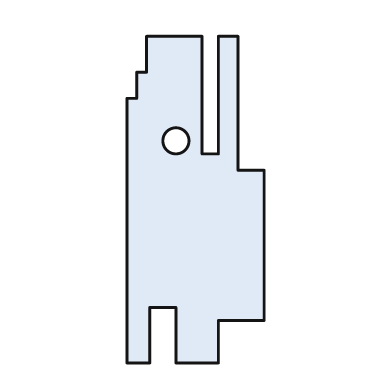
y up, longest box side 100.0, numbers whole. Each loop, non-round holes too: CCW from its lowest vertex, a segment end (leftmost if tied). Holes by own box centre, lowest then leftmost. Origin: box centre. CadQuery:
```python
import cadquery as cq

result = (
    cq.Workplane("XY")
    .moveTo(-21.0, -50.0)
    .lineTo(-14.0, -50.0)
    .lineTo(-14.0, -33.0)
    .lineTo(-6.0, -33.0)
    .lineTo(-6.0, -50.0)
    .lineTo(7.0, -50.0)
    .lineTo(7.0, -37.0)
    .lineTo(21.0, -37.0)
    .lineTo(21.0, 9.0)
    .lineTo(13.0, 9.0)
    .lineTo(13.0, 50.0)
    .lineTo(7.0, 50.0)
    .lineTo(7.0, 14.0)
    .lineTo(2.0, 14.0)
    .lineTo(2.0, 50.0)
    .lineTo(-15.0, 50.0)
    .lineTo(-15.0, 39.0)
    .lineTo(-18.0, 39.0)
    .lineTo(-18.0, 31.0)
    .lineTo(-21.0, 31.0)
    .close()
    .moveTo(-6.0, 18.0)
    .circle(4.0)
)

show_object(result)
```